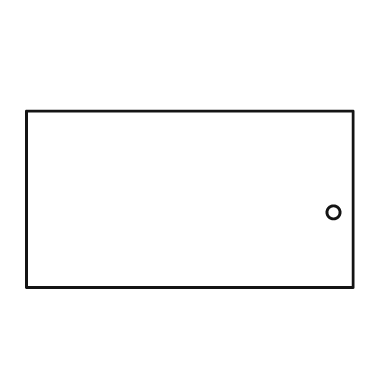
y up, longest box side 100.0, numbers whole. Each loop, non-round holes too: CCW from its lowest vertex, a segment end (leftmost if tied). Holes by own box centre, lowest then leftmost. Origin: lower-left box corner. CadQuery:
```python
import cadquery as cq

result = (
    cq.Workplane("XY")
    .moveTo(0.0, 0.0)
    .lineTo(100.0, 0.0)
    .lineTo(100.0, 54.0)
    .lineTo(0.0, 54.0)
    .close()
    .moveTo(94.0, 23.0)
    .circle(2.0)
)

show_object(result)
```